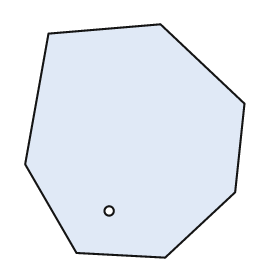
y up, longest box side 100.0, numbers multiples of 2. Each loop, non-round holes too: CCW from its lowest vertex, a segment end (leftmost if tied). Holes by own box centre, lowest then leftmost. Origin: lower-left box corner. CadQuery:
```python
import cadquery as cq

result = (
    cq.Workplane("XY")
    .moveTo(60.0, 0.0)
    .lineTo(90.0, 28.0)
    .lineTo(94.0, 66.0)
    .lineTo(58.0, 100.0)
    .lineTo(10.0, 96.0)
    .lineTo(0.0, 40.0)
    .lineTo(22.0, 2.0)
    .close()
    .moveTo(36.0, 20.0)
    .circle(2.0)
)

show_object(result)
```